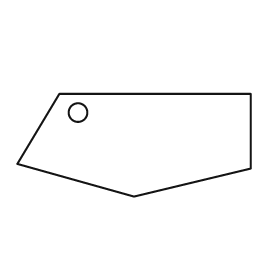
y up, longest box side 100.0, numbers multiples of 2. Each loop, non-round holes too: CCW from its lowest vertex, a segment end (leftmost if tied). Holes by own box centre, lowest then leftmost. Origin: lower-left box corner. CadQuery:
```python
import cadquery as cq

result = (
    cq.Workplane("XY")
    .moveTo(50.0, 0.0)
    .lineTo(100.0, 12.0)
    .lineTo(100.0, 44.0)
    .lineTo(18.0, 44.0)
    .lineTo(0.0, 14.0)
    .close()
    .moveTo(26.0, 36.0)
    .circle(4.0)
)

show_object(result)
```